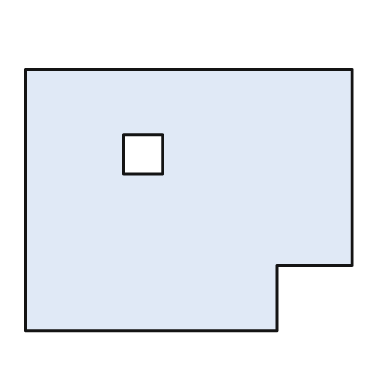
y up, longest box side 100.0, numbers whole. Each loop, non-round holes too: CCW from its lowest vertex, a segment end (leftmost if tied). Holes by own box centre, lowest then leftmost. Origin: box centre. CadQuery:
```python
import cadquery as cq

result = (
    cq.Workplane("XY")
    .moveTo(-50.0, -40.0)
    .lineTo(27.0, -40.0)
    .lineTo(27.0, -20.0)
    .lineTo(50.0, -20.0)
    .lineTo(50.0, 40.0)
    .lineTo(-50.0, 40.0)
    .close()
    .moveTo(-20.0, 8.0)
    .lineTo(-8.0, 8.0)
    .lineTo(-8.0, 20.0)
    .lineTo(-20.0, 20.0)
    .close()
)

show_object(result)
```